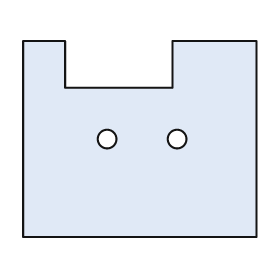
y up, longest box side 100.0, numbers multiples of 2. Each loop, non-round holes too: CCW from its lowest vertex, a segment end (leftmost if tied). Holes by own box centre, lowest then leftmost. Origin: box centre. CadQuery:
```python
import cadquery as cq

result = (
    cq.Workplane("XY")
    .moveTo(-50.0, -42.0)
    .lineTo(50.0, -42.0)
    .lineTo(50.0, 42.0)
    .lineTo(14.0, 42.0)
    .lineTo(14.0, 22.0)
    .lineTo(-32.0, 22.0)
    .lineTo(-32.0, 42.0)
    .lineTo(-50.0, 42.0)
    .close()
    .moveTo(-14.0, 0.0)
    .circle(4.0)
    .moveTo(16.0, 0.0)
    .circle(4.0)
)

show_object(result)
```